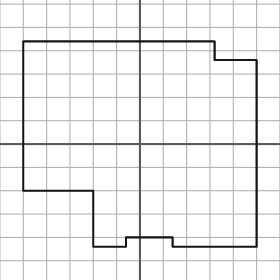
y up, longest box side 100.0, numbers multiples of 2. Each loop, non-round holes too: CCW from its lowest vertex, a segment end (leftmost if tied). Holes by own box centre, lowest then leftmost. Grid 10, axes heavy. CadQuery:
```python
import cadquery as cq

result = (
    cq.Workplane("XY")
    .moveTo(-20.0, -44.0)
    .lineTo(-6.0, -44.0)
    .lineTo(-6.0, -40.0)
    .lineTo(14.0, -40.0)
    .lineTo(14.0, -44.0)
    .lineTo(50.0, -44.0)
    .lineTo(50.0, 36.0)
    .lineTo(32.0, 36.0)
    .lineTo(32.0, 44.0)
    .lineTo(-50.0, 44.0)
    .lineTo(-50.0, -20.0)
    .lineTo(-20.0, -20.0)
    .close()
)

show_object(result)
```